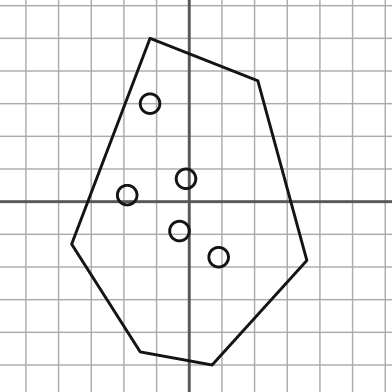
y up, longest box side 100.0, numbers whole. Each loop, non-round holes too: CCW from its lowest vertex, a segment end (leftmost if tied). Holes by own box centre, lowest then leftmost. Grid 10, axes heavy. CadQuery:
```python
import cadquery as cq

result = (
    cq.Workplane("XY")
    .moveTo(7.0, -50.0)
    .lineTo(36.0, -18.0)
    .lineTo(21.0, 37.0)
    .lineTo(-12.0, 50.0)
    .lineTo(-36.0, -13.0)
    .lineTo(-15.0, -46.0)
    .close()
    .moveTo(9.0, -17.0)
    .circle(3.0)
    .moveTo(-3.0, -9.0)
    .circle(3.0)
    .moveTo(-19.0, 2.0)
    .circle(3.0)
    .moveTo(-1.0, 7.0)
    .circle(3.0)
    .moveTo(-12.0, 30.0)
    .circle(3.0)
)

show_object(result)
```